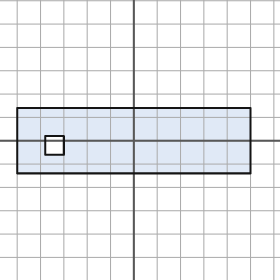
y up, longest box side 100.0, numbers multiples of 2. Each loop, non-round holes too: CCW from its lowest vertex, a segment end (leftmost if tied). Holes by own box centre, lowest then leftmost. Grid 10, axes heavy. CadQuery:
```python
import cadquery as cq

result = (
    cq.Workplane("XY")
    .moveTo(-50.0, -14.0)
    .lineTo(50.0, -14.0)
    .lineTo(50.0, 14.0)
    .lineTo(-50.0, 14.0)
    .close()
    .moveTo(-38.0, -6.0)
    .lineTo(-30.0, -6.0)
    .lineTo(-30.0, 2.0)
    .lineTo(-38.0, 2.0)
    .close()
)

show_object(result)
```